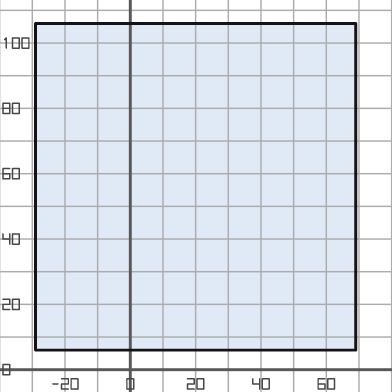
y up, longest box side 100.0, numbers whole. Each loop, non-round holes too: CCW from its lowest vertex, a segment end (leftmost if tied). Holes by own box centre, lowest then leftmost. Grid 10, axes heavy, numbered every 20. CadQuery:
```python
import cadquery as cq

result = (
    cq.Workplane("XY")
    .moveTo(-29.0, 6.0)
    .lineTo(69.0, 6.0)
    .lineTo(69.0, 106.0)
    .lineTo(-29.0, 106.0)
    .close()
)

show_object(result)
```